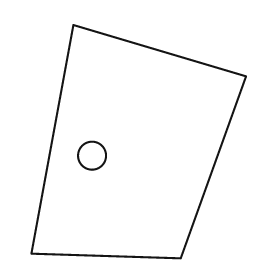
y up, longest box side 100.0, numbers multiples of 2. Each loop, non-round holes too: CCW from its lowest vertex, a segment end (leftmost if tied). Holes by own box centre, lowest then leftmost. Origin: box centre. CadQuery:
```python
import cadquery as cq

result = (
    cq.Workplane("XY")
    .moveTo(18.0, -50.0)
    .lineTo(46.0, 28.0)
    .lineTo(-28.0, 50.0)
    .lineTo(-46.0, -48.0)
    .close()
    .moveTo(-20.0, -6.0)
    .circle(6.0)
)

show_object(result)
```